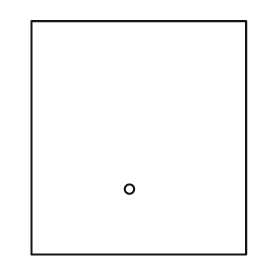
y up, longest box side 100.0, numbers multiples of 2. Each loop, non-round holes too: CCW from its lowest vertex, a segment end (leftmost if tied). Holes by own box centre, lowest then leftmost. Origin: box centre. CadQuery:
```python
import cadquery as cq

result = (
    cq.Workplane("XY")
    .moveTo(-46.0, -50.0)
    .lineTo(46.0, -50.0)
    .lineTo(46.0, 50.0)
    .lineTo(-46.0, 50.0)
    .close()
    .moveTo(-4.0, -22.0)
    .circle(2.0)
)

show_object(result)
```